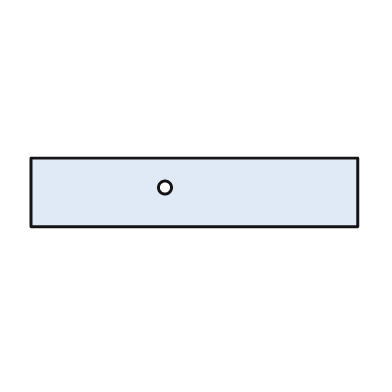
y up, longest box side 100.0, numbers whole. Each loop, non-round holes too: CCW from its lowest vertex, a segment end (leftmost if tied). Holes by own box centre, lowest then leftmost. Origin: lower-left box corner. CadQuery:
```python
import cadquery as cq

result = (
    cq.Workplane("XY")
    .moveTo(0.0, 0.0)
    .lineTo(100.0, 0.0)
    .lineTo(100.0, 21.0)
    .lineTo(0.0, 21.0)
    .close()
    .moveTo(41.0, 12.0)
    .circle(2.0)
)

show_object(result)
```